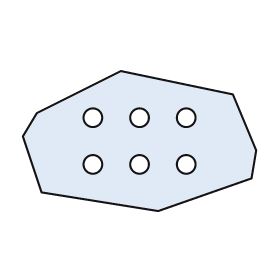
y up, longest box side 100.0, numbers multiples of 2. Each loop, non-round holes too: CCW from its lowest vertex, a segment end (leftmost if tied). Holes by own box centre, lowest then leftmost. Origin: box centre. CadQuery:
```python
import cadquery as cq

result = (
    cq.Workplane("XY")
    .moveTo(8.0, -30.0)
    .lineTo(48.0, -16.0)
    .lineTo(50.0, -4.0)
    .lineTo(40.0, 20.0)
    .lineTo(-8.0, 30.0)
    .lineTo(-44.0, 12.0)
    .lineTo(-50.0, 2.0)
    .lineTo(-42.0, -22.0)
    .close()
    .moveTo(-20.0, -10.0)
    .circle(4.0)
    .moveTo(0.0, -10.0)
    .circle(4.0)
    .moveTo(20.0, -10.0)
    .circle(4.0)
    .moveTo(-20.0, 10.0)
    .circle(4.0)
    .moveTo(0.0, 10.0)
    .circle(4.0)
    .moveTo(20.0, 10.0)
    .circle(4.0)
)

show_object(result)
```